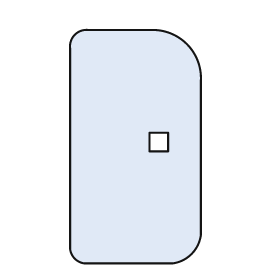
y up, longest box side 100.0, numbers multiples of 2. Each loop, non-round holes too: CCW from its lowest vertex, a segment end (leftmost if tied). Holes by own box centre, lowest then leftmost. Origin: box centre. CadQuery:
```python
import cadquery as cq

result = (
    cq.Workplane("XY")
    .moveTo(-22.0, -50.0)
    .lineTo(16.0, -50.0)
    .threePointArc((24.0, -46.0), (28.0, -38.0))
    .lineTo(28.0, 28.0)
    .threePointArc((22.0, 44.0), (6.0, 50.0))
    .lineTo(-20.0, 50.0)
    .threePointArc((-26.0, 48.0), (-28.0, 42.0))
    .lineTo(-28.0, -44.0)
    .threePointArc((-26.0, -48.0), (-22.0, -50.0))
    .close()
    .moveTo(6.0, -2.0)
    .lineTo(14.0, -2.0)
    .lineTo(14.0, 6.0)
    .lineTo(6.0, 6.0)
    .close()
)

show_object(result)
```